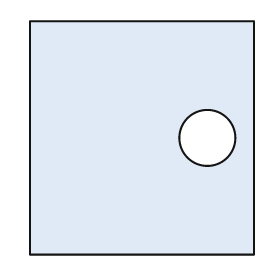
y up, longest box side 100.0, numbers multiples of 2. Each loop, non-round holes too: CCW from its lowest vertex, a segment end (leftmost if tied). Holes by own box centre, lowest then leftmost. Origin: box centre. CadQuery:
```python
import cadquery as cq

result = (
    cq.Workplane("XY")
    .moveTo(-48.0, -50.0)
    .lineTo(48.0, -50.0)
    .lineTo(48.0, 50.0)
    .lineTo(-48.0, 50.0)
    .close()
    .moveTo(28.0, 0.0)
    .circle(12.0)
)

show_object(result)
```